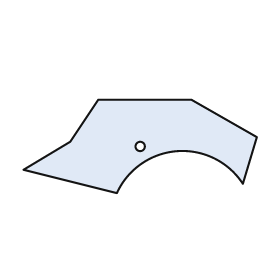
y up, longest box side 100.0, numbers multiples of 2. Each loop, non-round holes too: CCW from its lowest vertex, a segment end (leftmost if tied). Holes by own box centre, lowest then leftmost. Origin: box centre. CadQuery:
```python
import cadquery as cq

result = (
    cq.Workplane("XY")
    .moveTo(-10.0, -20.0)
    .threePointArc((16.0, -2.0), (44.0, -16.0))
    .lineTo(50.0, 4.0)
    .lineTo(22.0, 20.0)
    .lineTo(-18.0, 20.0)
    .lineTo(-30.0, 2.0)
    .lineTo(-50.0, -10.0)
    .close()
    .moveTo(0.0, 0.0)
    .circle(2.0)
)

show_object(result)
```